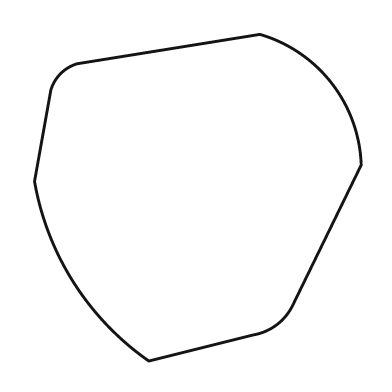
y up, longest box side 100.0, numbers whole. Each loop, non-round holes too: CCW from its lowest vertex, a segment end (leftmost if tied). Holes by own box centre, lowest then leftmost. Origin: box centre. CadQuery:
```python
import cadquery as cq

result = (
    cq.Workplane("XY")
    .moveTo(-15.0, -50.0)
    .lineTo(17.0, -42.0)
    .threePointArc((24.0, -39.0), (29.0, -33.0))
    .lineTo(50.0, 10.0)
    .threePointArc((41.0, 35.0), (19.0, 50.0))
    .lineTo(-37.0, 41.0)
    .threePointArc((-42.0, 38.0), (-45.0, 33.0))
    .lineTo(-50.0, 5.0)
    .threePointArc((-38.0, -26.0), (-15.0, -50.0))
    .close()
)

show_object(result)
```